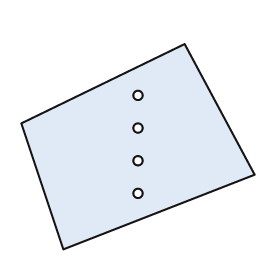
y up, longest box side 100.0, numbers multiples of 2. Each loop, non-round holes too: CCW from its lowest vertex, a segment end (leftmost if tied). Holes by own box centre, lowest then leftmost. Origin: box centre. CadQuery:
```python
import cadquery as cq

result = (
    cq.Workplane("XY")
    .moveTo(-32.0, -44.0)
    .lineTo(50.0, -12.0)
    .lineTo(20.0, 44.0)
    .lineTo(-50.0, 10.0)
    .close()
    .moveTo(0.0, -20.0)
    .circle(2.0)
    .moveTo(0.0, -6.0)
    .circle(2.0)
    .moveTo(0.0, 8.0)
    .circle(2.0)
    .moveTo(0.0, 22.0)
    .circle(2.0)
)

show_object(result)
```